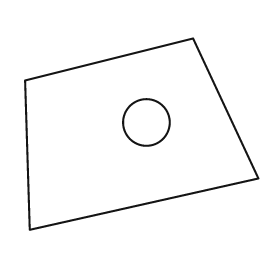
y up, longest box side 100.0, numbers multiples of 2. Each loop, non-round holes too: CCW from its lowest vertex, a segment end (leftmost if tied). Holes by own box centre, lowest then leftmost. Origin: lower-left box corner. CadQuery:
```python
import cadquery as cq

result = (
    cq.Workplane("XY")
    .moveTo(2.0, 0.0)
    .lineTo(100.0, 22.0)
    .lineTo(72.0, 82.0)
    .lineTo(0.0, 64.0)
    .close()
    .moveTo(52.0, 46.0)
    .circle(10.0)
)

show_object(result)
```